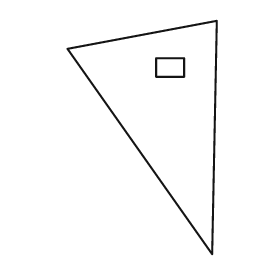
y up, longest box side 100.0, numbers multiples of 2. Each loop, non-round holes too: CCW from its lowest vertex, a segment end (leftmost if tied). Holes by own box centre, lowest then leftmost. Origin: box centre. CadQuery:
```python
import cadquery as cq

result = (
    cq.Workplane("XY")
    .moveTo(30.0, -50.0)
    .lineTo(32.0, 50.0)
    .lineTo(-32.0, 38.0)
    .close()
    .moveTo(6.0, 26.0)
    .lineTo(18.0, 26.0)
    .lineTo(18.0, 34.0)
    .lineTo(6.0, 34.0)
    .close()
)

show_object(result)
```